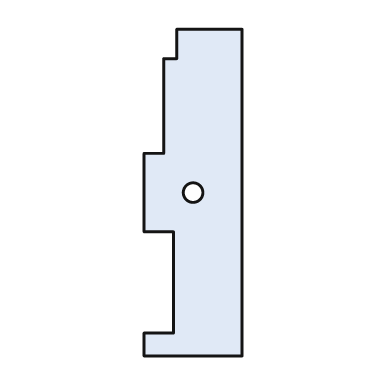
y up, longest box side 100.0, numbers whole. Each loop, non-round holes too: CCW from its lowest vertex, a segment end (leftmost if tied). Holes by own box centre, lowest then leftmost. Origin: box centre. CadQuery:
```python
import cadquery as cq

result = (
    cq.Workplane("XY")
    .moveTo(-15.0, -50.0)
    .lineTo(15.0, -50.0)
    .lineTo(15.0, 50.0)
    .lineTo(-5.0, 50.0)
    .lineTo(-5.0, 41.0)
    .lineTo(-9.0, 41.0)
    .lineTo(-9.0, 12.0)
    .lineTo(-15.0, 12.0)
    .lineTo(-15.0, -12.0)
    .lineTo(-6.0, -12.0)
    .lineTo(-6.0, -43.0)
    .lineTo(-15.0, -43.0)
    .close()
    .moveTo(0.0, 0.0)
    .circle(3.0)
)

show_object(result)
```